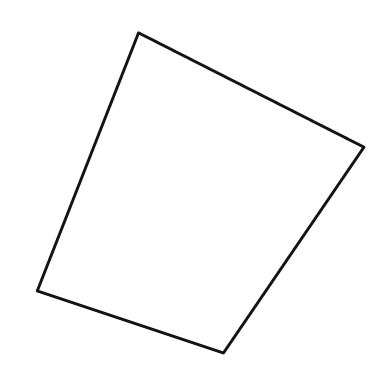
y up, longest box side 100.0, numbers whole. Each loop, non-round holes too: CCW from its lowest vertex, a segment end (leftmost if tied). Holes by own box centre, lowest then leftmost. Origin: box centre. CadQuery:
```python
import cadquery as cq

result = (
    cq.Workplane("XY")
    .moveTo(7.0, -49.0)
    .lineTo(50.0, 14.0)
    .lineTo(-19.0, 49.0)
    .lineTo(-50.0, -30.0)
    .close()
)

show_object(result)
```